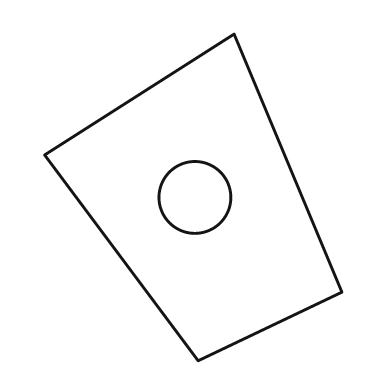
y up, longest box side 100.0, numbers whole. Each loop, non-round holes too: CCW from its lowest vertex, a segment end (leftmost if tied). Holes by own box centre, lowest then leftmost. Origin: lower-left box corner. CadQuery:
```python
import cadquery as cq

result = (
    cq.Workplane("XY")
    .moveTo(47.0, 0.0)
    .lineTo(91.0, 21.0)
    .lineTo(58.0, 100.0)
    .lineTo(0.0, 63.0)
    .close()
    .moveTo(46.0, 50.0)
    .circle(11.0)
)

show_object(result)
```